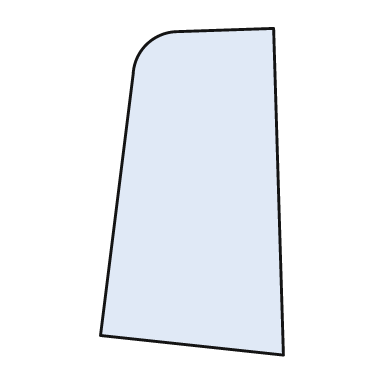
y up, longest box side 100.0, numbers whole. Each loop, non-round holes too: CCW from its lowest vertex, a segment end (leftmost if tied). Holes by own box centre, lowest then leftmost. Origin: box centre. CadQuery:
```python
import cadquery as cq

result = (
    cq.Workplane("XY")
    .moveTo(28.0, -50.0)
    .lineTo(25.0, 50.0)
    .lineTo(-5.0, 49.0)
    .threePointArc((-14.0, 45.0), (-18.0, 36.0))
    .lineTo(-28.0, -44.0)
    .close()
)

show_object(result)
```